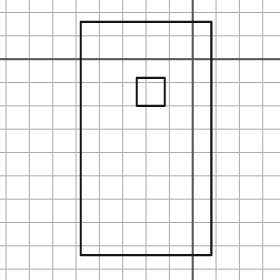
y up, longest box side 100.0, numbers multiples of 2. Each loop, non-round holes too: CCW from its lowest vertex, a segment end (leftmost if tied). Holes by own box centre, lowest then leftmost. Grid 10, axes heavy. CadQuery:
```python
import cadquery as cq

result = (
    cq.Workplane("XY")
    .moveTo(-48.0, -84.0)
    .lineTo(8.0, -84.0)
    .lineTo(8.0, 16.0)
    .lineTo(-48.0, 16.0)
    .close()
    .moveTo(-24.0, -20.0)
    .lineTo(-12.0, -20.0)
    .lineTo(-12.0, -8.0)
    .lineTo(-24.0, -8.0)
    .close()
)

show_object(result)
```